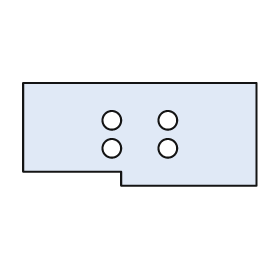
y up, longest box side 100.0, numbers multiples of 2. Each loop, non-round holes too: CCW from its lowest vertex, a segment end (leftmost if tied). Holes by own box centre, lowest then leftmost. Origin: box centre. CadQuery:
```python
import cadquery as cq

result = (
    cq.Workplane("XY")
    .moveTo(-8.0, -22.0)
    .lineTo(50.0, -22.0)
    .lineTo(50.0, 22.0)
    .lineTo(-50.0, 22.0)
    .lineTo(-50.0, -16.0)
    .lineTo(-8.0, -16.0)
    .close()
    .moveTo(-12.0, -6.0)
    .circle(4.0)
    .moveTo(12.0, -6.0)
    .circle(4.0)
    .moveTo(-12.0, 6.0)
    .circle(4.0)
    .moveTo(12.0, 6.0)
    .circle(4.0)
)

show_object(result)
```